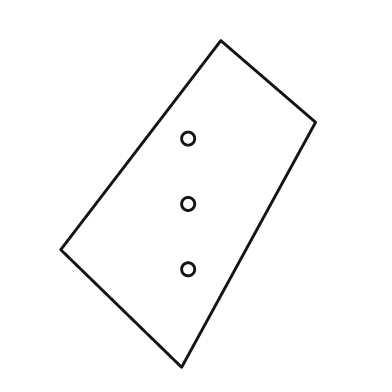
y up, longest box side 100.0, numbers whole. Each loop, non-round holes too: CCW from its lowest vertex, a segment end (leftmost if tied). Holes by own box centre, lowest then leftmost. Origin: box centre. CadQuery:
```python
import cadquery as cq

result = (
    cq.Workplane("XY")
    .moveTo(-2.0, -50.0)
    .lineTo(39.0, 25.0)
    .lineTo(10.0, 50.0)
    .lineTo(-39.0, -14.0)
    .close()
    .moveTo(0.0, -20.0)
    .circle(2.0)
    .moveTo(0.0, 0.0)
    .circle(2.0)
    .moveTo(0.0, 20.0)
    .circle(2.0)
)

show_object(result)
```